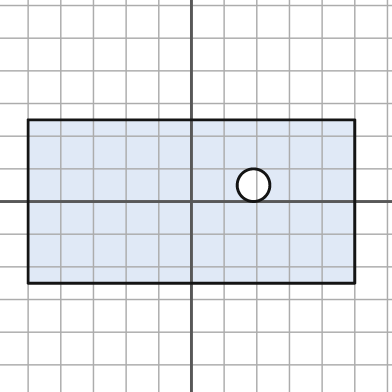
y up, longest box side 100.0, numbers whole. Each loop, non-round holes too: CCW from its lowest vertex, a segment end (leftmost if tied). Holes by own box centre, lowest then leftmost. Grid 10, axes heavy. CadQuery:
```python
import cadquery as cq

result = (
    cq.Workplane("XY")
    .moveTo(-50.0, -25.0)
    .lineTo(50.0, -25.0)
    .lineTo(50.0, 25.0)
    .lineTo(-50.0, 25.0)
    .close()
    .moveTo(19.0, 5.0)
    .circle(5.0)
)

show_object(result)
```